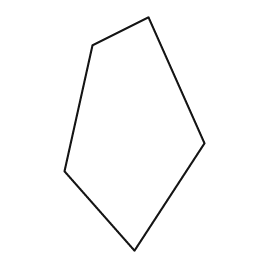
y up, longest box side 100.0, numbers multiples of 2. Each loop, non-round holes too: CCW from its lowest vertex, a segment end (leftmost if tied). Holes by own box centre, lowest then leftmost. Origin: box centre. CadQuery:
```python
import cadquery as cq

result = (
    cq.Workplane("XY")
    .moveTo(0.0, -50.0)
    .lineTo(30.0, -4.0)
    .lineTo(6.0, 50.0)
    .lineTo(-18.0, 38.0)
    .lineTo(-30.0, -16.0)
    .close()
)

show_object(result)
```